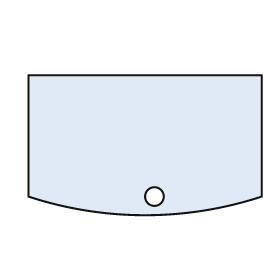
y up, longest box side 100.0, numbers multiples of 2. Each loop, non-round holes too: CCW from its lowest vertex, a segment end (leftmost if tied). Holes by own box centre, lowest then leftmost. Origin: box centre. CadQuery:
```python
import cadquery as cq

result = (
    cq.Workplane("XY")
    .moveTo(-50.0, -22.0)
    .threePointArc((0.0, -30.0), (50.0, -22.0))
    .lineTo(50.0, 30.0)
    .lineTo(-50.0, 30.0)
    .close()
    .moveTo(4.0, -22.0)
    .circle(4.0)
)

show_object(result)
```